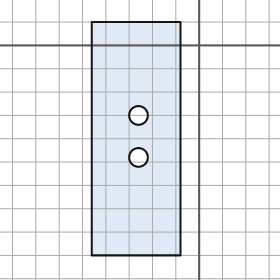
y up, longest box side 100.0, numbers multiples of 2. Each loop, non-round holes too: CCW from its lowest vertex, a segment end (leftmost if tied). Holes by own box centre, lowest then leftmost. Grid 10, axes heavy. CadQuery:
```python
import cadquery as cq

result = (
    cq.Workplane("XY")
    .moveTo(-46.0, -90.0)
    .lineTo(-8.0, -90.0)
    .lineTo(-8.0, 10.0)
    .lineTo(-46.0, 10.0)
    .close()
    .moveTo(-26.0, -48.0)
    .circle(4.0)
    .moveTo(-26.0, -30.0)
    .circle(4.0)
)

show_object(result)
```